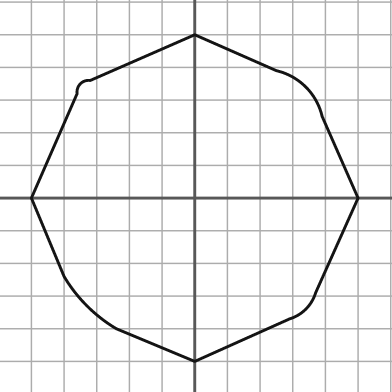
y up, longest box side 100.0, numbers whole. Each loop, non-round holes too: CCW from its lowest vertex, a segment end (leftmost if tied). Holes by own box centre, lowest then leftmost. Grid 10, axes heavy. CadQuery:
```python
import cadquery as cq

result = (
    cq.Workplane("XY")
    .moveTo(0.0, -50.0)
    .lineTo(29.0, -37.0)
    .threePointArc((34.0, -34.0), (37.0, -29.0))
    .lineTo(50.0, 0.0)
    .lineTo(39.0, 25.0)
    .threePointArc((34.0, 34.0), (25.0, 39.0))
    .lineTo(0.0, 50.0)
    .lineTo(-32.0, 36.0)
    .threePointArc((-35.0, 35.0), (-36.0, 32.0))
    .lineTo(-50.0, 0.0)
    .lineTo(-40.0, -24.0)
    .threePointArc((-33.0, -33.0), (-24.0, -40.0))
    .close()
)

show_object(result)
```